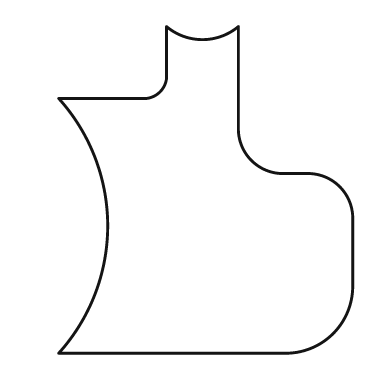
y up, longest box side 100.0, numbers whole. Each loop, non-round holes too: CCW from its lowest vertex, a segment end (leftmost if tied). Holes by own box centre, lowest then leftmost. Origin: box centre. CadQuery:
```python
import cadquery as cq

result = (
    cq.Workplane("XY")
    .moveTo(-45.0, -50.0)
    .lineTo(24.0, -50.0)
    .threePointArc((39.0, -44.0), (45.0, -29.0))
    .lineTo(45.0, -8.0)
    .threePointArc((41.0, 1.0), (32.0, 5.0))
    .lineTo(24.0, 5.0)
    .threePointArc((14.0, 9.0), (10.0, 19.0))
    .lineTo(10.0, 50.0)
    .threePointArc((-1.0, 46.0), (-12.0, 50.0))
    .lineTo(-12.0, 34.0)
    .threePointArc((-14.0, 30.0), (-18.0, 28.0))
    .lineTo(-45.0, 28.0)
    .threePointArc((-30.0, -11.0), (-45.0, -50.0))
    .close()
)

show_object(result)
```